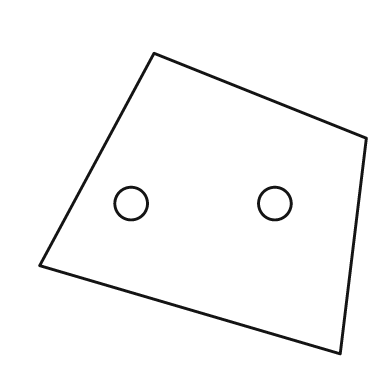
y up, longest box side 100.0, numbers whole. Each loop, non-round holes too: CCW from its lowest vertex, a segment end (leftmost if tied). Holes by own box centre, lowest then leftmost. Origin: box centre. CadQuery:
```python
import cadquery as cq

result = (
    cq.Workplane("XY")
    .moveTo(42.0, -46.0)
    .lineTo(50.0, 20.0)
    .lineTo(-15.0, 46.0)
    .lineTo(-50.0, -19.0)
    .close()
    .moveTo(-22.0, 0.0)
    .circle(5.0)
    .moveTo(22.0, 0.0)
    .circle(5.0)
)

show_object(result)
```